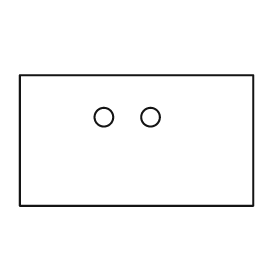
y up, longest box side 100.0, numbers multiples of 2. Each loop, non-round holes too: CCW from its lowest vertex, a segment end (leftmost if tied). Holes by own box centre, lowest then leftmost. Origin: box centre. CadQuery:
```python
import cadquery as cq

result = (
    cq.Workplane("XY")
    .moveTo(-50.0, -28.0)
    .lineTo(50.0, -28.0)
    .lineTo(50.0, 28.0)
    .lineTo(-50.0, 28.0)
    .close()
    .moveTo(-14.0, 10.0)
    .circle(4.0)
    .moveTo(6.0, 10.0)
    .circle(4.0)
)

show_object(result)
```